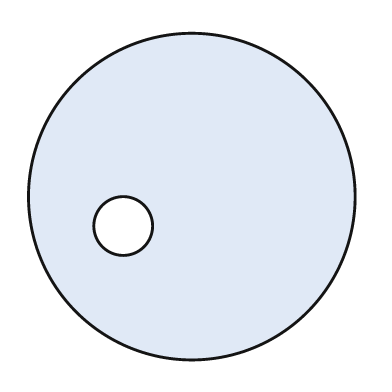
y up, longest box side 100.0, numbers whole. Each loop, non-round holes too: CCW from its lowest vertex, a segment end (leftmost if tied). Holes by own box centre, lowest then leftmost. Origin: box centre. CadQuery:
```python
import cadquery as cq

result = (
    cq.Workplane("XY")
    .moveTo(0.0, 0.0)
    .circle(50.0)
    .moveTo(-21.0, -9.0)
    .circle(9.0)
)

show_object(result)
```